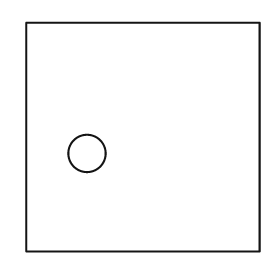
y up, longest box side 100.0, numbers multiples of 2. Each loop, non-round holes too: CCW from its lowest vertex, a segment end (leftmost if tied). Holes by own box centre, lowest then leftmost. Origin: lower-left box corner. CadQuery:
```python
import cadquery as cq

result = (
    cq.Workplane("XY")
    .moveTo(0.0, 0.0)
    .lineTo(100.0, 0.0)
    .lineTo(100.0, 98.0)
    .lineTo(0.0, 98.0)
    .close()
    .moveTo(26.0, 42.0)
    .circle(8.0)
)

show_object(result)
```